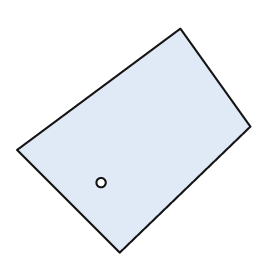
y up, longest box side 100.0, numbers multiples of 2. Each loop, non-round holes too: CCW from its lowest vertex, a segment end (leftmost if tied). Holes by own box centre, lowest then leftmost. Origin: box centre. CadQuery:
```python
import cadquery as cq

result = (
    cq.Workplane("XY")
    .moveTo(-6.0, -48.0)
    .lineTo(50.0, 6.0)
    .lineTo(20.0, 48.0)
    .lineTo(-50.0, -4.0)
    .close()
    .moveTo(-14.0, -18.0)
    .circle(2.0)
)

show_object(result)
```